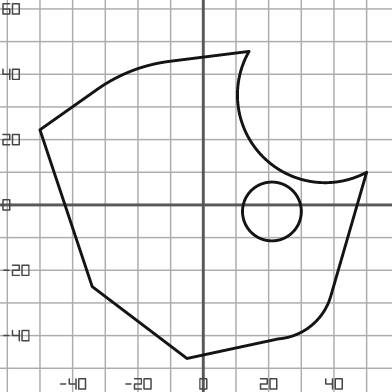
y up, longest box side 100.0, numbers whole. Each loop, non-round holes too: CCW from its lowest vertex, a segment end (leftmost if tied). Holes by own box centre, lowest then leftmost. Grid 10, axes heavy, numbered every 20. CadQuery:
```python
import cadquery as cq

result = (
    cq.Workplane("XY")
    .moveTo(-5.0, -47.0)
    .lineTo(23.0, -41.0)
    .threePointArc((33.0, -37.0), (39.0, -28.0))
    .lineTo(50.0, 10.0)
    .threePointArc((18.0, 15.0), (14.0, 47.0))
    .lineTo(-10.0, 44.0)
    .threePointArc((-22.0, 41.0), (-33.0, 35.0))
    .lineTo(-50.0, 23.0)
    .lineTo(-34.0, -25.0)
    .close()
    .moveTo(21.0, -2.0)
    .circle(9.0)
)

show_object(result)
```